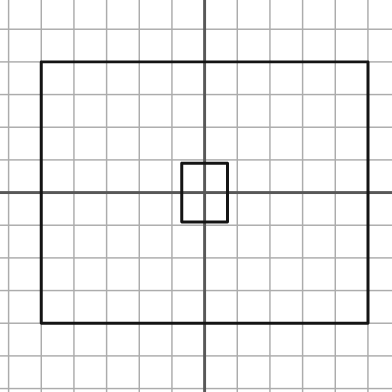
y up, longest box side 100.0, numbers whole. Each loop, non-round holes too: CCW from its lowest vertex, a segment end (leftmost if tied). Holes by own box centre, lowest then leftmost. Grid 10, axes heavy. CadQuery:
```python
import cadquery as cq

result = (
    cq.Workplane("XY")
    .moveTo(-50.0, -40.0)
    .lineTo(50.0, -40.0)
    .lineTo(50.0, 40.0)
    .lineTo(-50.0, 40.0)
    .close()
    .moveTo(-7.0, -9.0)
    .lineTo(7.0, -9.0)
    .lineTo(7.0, 9.0)
    .lineTo(-7.0, 9.0)
    .close()
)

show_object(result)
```